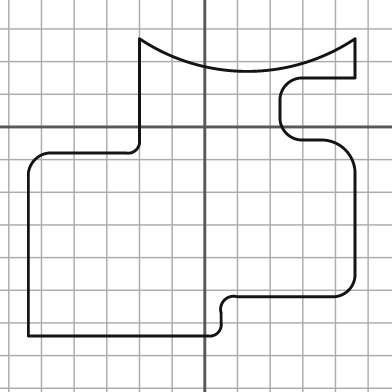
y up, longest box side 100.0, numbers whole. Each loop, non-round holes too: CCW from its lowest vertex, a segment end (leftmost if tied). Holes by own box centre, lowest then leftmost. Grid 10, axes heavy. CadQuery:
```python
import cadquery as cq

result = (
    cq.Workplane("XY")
    .moveTo(-54.0, -64.0)
    .lineTo(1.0, -64.0)
    .threePointArc((4.0, -63.0), (5.0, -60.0))
    .lineTo(5.0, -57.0)
    .threePointArc((6.0, -53.0), (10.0, -52.0))
    .lineTo(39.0, -52.0)
    .threePointArc((44.0, -50.0), (46.0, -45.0))
    .lineTo(46.0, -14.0)
    .threePointArc((43.0, -7.0), (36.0, -4.0))
    .lineTo(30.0, -4.0)
    .threePointArc((25.0, -2.0), (23.0, 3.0))
    .lineTo(23.0, 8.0)
    .threePointArc((25.0, 13.0), (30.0, 15.0))
    .lineTo(46.0, 15.0)
    .lineTo(46.0, 27.0)
    .threePointArc((13.0, 17.0), (-20.0, 27.0))
    .lineTo(-20.0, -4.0)
    .threePointArc((-21.0, -7.0), (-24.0, -8.0))
    .lineTo(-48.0, -8.0)
    .threePointArc((-52.0, -10.0), (-54.0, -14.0))
    .close()
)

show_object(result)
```